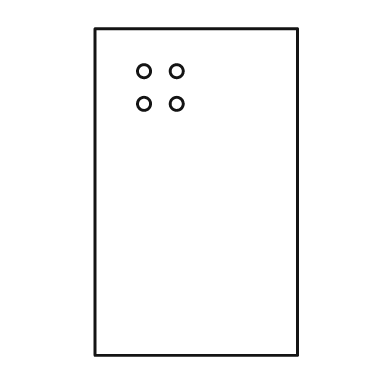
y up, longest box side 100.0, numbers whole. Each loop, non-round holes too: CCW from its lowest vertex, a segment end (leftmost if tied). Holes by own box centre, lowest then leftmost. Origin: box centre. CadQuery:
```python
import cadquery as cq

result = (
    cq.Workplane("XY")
    .moveTo(-31.0, -50.0)
    .lineTo(31.0, -50.0)
    .lineTo(31.0, 50.0)
    .lineTo(-31.0, 50.0)
    .close()
    .moveTo(-16.0, 27.0)
    .circle(2.0)
    .moveTo(-6.0, 27.0)
    .circle(2.0)
    .moveTo(-16.0, 37.0)
    .circle(2.0)
    .moveTo(-6.0, 37.0)
    .circle(2.0)
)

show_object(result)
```